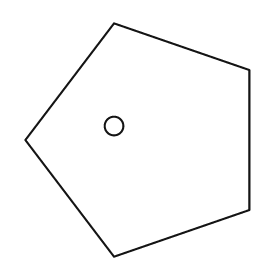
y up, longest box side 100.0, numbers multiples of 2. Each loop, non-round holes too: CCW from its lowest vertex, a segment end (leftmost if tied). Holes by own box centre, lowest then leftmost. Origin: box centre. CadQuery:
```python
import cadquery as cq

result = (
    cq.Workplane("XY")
    .moveTo(-10.0, -50.0)
    .lineTo(48.0, -30.0)
    .lineTo(48.0, 30.0)
    .lineTo(-10.0, 50.0)
    .lineTo(-48.0, 0.0)
    .close()
    .moveTo(-10.0, 6.0)
    .circle(4.0)
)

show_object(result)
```